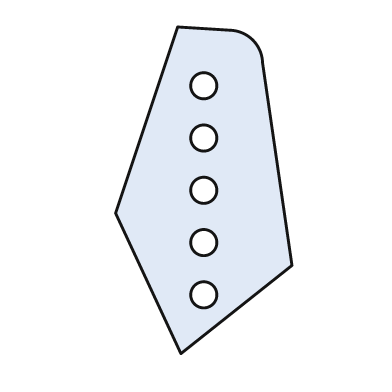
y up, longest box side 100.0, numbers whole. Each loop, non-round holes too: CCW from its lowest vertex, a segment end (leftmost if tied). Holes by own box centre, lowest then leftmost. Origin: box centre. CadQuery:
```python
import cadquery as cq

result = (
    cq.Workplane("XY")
    .moveTo(-7.0, -50.0)
    .lineTo(27.0, -23.0)
    .lineTo(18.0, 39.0)
    .threePointArc((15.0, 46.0), (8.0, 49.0))
    .lineTo(-8.0, 50.0)
    .lineTo(-27.0, -7.0)
    .close()
    .moveTo(0.0, -32.0)
    .circle(4.0)
    .moveTo(0.0, -16.0)
    .circle(4.0)
    .moveTo(0.0, 0.0)
    .circle(4.0)
    .moveTo(0.0, 16.0)
    .circle(4.0)
    .moveTo(0.0, 32.0)
    .circle(4.0)
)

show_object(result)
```